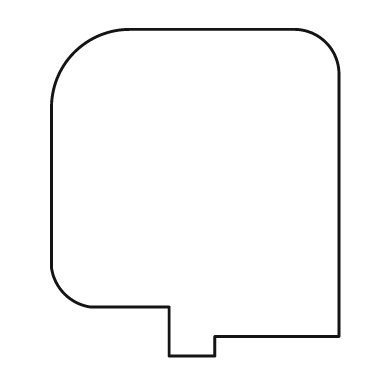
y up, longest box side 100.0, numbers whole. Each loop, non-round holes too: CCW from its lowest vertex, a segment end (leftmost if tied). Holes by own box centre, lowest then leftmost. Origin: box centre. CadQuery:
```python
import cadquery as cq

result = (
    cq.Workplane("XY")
    .moveTo(-8.0, -50.0)
    .lineTo(6.0, -50.0)
    .lineTo(6.0, -44.0)
    .lineTo(44.0, -44.0)
    .lineTo(44.0, 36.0)
    .threePointArc((40.0, 46.0), (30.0, 50.0))
    .lineTo(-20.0, 50.0)
    .threePointArc((-37.0, 43.0), (-44.0, 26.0))
    .lineTo(-44.0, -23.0)
    .threePointArc((-40.0, -31.0), (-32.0, -35.0))
    .lineTo(-8.0, -35.0)
    .close()
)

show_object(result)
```